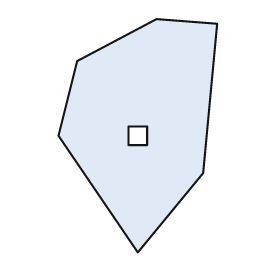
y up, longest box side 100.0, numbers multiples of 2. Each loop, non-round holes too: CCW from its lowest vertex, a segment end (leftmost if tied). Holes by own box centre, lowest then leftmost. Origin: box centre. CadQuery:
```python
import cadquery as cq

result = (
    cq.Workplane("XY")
    .moveTo(0.0, -50.0)
    .lineTo(28.0, -16.0)
    .lineTo(34.0, 48.0)
    .lineTo(8.0, 50.0)
    .lineTo(-26.0, 32.0)
    .lineTo(-34.0, 0.0)
    .close()
    .moveTo(-4.0, -4.0)
    .lineTo(4.0, -4.0)
    .lineTo(4.0, 4.0)
    .lineTo(-4.0, 4.0)
    .close()
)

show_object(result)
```